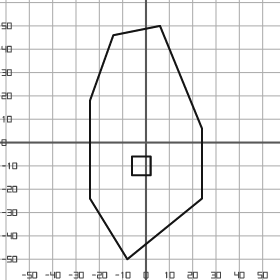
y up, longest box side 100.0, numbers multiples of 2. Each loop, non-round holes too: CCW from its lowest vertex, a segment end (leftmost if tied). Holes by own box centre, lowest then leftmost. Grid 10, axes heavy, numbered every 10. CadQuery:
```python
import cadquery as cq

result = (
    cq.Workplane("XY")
    .moveTo(-8.0, -50.0)
    .lineTo(24.0, -24.0)
    .lineTo(24.0, 6.0)
    .lineTo(6.0, 50.0)
    .lineTo(-14.0, 46.0)
    .lineTo(-24.0, 18.0)
    .lineTo(-24.0, -24.0)
    .close()
    .moveTo(-6.0, -14.0)
    .lineTo(2.0, -14.0)
    .lineTo(2.0, -6.0)
    .lineTo(-6.0, -6.0)
    .close()
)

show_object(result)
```